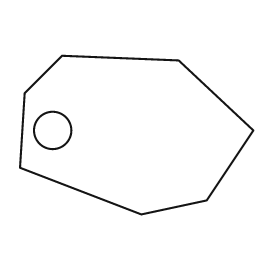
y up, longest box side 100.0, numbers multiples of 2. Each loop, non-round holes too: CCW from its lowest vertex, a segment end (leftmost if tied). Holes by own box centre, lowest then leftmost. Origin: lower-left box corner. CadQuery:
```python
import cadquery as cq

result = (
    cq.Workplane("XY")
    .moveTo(52.0, 0.0)
    .lineTo(80.0, 6.0)
    .lineTo(100.0, 36.0)
    .lineTo(68.0, 66.0)
    .lineTo(18.0, 68.0)
    .lineTo(2.0, 52.0)
    .lineTo(0.0, 20.0)
    .close()
    .moveTo(14.0, 36.0)
    .circle(8.0)
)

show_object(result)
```